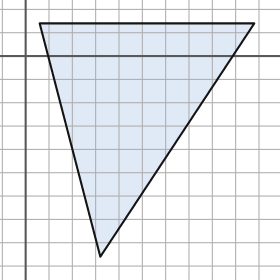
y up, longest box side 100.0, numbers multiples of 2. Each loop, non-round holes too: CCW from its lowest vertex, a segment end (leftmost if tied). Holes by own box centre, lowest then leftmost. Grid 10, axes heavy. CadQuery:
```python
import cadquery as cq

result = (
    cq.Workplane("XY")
    .moveTo(32.0, -86.0)
    .lineTo(98.0, 14.0)
    .lineTo(6.0, 14.0)
    .close()
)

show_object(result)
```